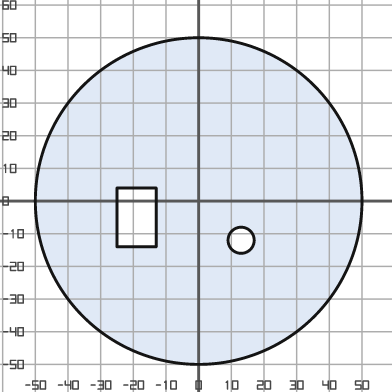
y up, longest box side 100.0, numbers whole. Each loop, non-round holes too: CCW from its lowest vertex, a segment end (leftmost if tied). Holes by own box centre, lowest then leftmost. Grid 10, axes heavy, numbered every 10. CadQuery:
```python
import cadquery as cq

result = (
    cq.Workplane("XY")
    .moveTo(0.0, 0.0)
    .circle(50.0)
    .moveTo(13.0, -12.0)
    .circle(4.0)
    .moveTo(-25.0, -14.0)
    .lineTo(-13.0, -14.0)
    .lineTo(-13.0, 4.0)
    .lineTo(-25.0, 4.0)
    .close()
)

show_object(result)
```